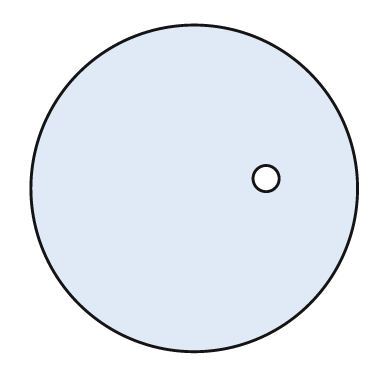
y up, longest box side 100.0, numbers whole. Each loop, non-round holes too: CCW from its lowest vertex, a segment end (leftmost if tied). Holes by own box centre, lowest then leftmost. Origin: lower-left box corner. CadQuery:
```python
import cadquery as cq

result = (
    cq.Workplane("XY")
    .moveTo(50.0, 50.0)
    .circle(50.0)
    .moveTo(72.0, 53.0)
    .circle(4.0)
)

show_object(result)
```